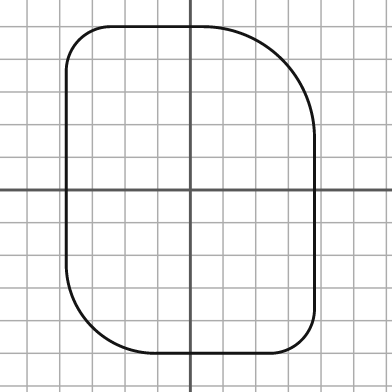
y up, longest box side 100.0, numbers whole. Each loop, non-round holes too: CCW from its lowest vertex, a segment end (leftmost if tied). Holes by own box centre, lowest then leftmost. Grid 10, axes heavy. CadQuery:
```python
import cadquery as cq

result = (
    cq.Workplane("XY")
    .moveTo(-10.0, -50.0)
    .lineTo(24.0, -50.0)
    .threePointArc((34.0, -46.0), (38.0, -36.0))
    .lineTo(38.0, 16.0)
    .threePointArc((28.0, 40.0), (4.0, 50.0))
    .lineTo(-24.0, 50.0)
    .threePointArc((-34.0, 46.0), (-38.0, 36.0))
    .lineTo(-38.0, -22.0)
    .threePointArc((-30.0, -42.0), (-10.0, -50.0))
    .close()
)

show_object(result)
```